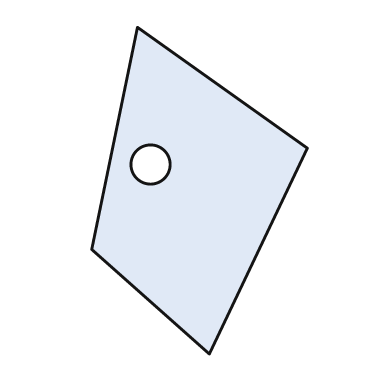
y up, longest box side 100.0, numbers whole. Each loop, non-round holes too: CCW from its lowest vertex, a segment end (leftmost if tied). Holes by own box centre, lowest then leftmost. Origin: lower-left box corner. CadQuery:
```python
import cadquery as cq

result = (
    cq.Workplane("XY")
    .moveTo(36.0, 0.0)
    .lineTo(66.0, 63.0)
    .lineTo(14.0, 100.0)
    .lineTo(0.0, 32.0)
    .close()
    .moveTo(18.0, 58.0)
    .circle(6.0)
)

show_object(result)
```